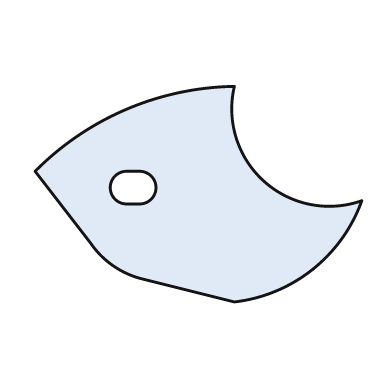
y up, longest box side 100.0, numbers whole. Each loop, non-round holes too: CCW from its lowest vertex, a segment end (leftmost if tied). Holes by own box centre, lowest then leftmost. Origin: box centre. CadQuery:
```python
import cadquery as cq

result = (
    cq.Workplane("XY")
    .moveTo(11.0, -33.0)
    .threePointArc((35.0, -23.0), (50.0, -2.0))
    .threePointArc((20.0, 4.0), (11.0, 33.0))
    .threePointArc((-22.0, 26.0), (-50.0, 7.0))
    .lineTo(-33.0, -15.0)
    .threePointArc((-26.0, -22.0), (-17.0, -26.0))
    .close()
    .moveTo(-22.0, -3.0)
    .lineTo(-18.0, -3.0)
    .threePointArc((-13.0, 2.0), (-18.0, 7.0))
    .lineTo(-22.0, 7.0)
    .threePointArc((-27.0, 2.0), (-22.0, -3.0))
    .close()
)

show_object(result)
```